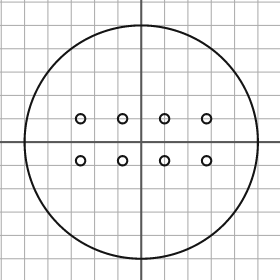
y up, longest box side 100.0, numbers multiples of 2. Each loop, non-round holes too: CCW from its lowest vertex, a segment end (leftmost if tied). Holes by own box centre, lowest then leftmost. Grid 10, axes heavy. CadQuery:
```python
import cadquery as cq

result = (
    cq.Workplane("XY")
    .moveTo(0.0, 0.0)
    .circle(50.0)
    .moveTo(-26.0, -8.0)
    .circle(2.0)
    .moveTo(-8.0, -8.0)
    .circle(2.0)
    .moveTo(10.0, -8.0)
    .circle(2.0)
    .moveTo(28.0, -8.0)
    .circle(2.0)
    .moveTo(-26.0, 10.0)
    .circle(2.0)
    .moveTo(-8.0, 10.0)
    .circle(2.0)
    .moveTo(10.0, 10.0)
    .circle(2.0)
    .moveTo(28.0, 10.0)
    .circle(2.0)
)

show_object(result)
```